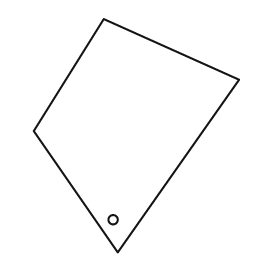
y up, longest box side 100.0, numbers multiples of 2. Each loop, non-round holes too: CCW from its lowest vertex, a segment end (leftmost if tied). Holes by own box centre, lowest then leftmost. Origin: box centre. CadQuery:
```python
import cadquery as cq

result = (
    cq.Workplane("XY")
    .moveTo(-8.0, -50.0)
    .lineTo(44.0, 24.0)
    .lineTo(-14.0, 50.0)
    .lineTo(-44.0, 2.0)
    .close()
    .moveTo(-10.0, -36.0)
    .circle(2.0)
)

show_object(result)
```